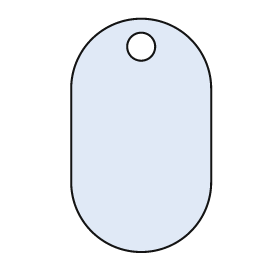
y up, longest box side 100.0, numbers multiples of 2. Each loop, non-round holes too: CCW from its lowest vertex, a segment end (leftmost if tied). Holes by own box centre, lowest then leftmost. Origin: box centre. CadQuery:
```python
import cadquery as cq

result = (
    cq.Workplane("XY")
    .moveTo(-30.0, -20.0)
    .threePointArc((0.0, -50.0), (30.0, -20.0))
    .lineTo(30.0, 20.0)
    .threePointArc((0.0, 50.0), (-30.0, 20.0))
    .close()
    .moveTo(0.0, 38.0)
    .circle(6.0)
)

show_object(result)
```